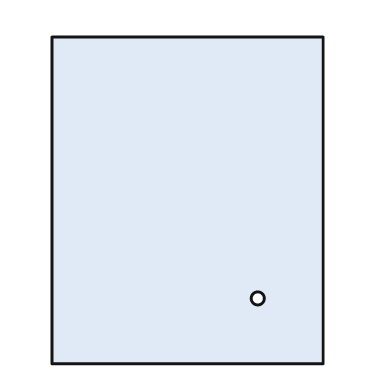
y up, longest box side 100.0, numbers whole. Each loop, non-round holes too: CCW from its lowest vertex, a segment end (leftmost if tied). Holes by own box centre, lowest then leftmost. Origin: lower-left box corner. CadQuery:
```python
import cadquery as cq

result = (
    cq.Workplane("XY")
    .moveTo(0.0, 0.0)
    .lineTo(83.0, 0.0)
    .lineTo(83.0, 100.0)
    .lineTo(0.0, 100.0)
    .close()
    .moveTo(63.0, 20.0)
    .circle(2.0)
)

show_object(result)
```